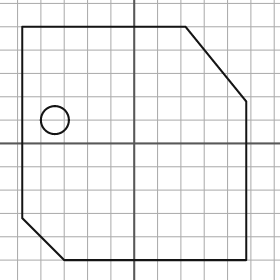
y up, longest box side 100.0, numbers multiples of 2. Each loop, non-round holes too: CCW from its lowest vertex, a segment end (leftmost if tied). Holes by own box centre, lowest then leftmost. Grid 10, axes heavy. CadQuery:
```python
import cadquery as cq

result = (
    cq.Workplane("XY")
    .moveTo(-30.0, -50.0)
    .lineTo(48.0, -50.0)
    .lineTo(48.0, 18.0)
    .lineTo(22.0, 50.0)
    .lineTo(-48.0, 50.0)
    .lineTo(-48.0, -32.0)
    .close()
    .moveTo(-34.0, 10.0)
    .circle(6.0)
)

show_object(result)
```